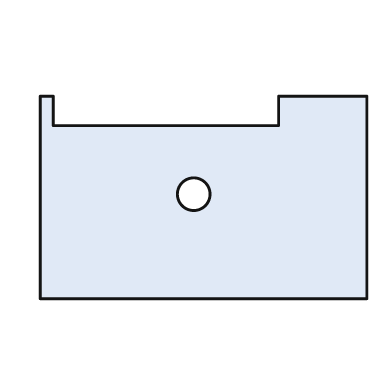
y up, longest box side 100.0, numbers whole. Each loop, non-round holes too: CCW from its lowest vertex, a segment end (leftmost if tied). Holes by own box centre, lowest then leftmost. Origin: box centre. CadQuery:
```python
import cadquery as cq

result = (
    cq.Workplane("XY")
    .moveTo(-50.0, -31.0)
    .lineTo(50.0, -31.0)
    .lineTo(50.0, 31.0)
    .lineTo(23.0, 31.0)
    .lineTo(23.0, 22.0)
    .lineTo(-46.0, 22.0)
    .lineTo(-46.0, 31.0)
    .lineTo(-50.0, 31.0)
    .close()
    .moveTo(-3.0, 1.0)
    .circle(5.0)
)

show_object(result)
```